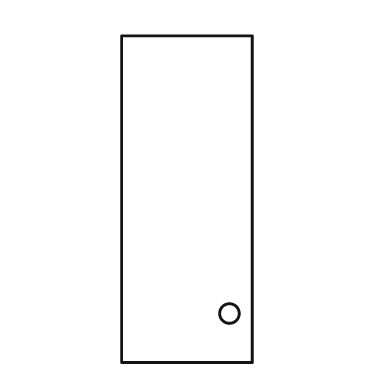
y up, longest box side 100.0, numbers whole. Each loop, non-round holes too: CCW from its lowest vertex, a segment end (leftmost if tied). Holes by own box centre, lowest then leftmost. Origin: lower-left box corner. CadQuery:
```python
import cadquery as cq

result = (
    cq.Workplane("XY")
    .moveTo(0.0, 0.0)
    .lineTo(40.0, 0.0)
    .lineTo(40.0, 100.0)
    .lineTo(0.0, 100.0)
    .close()
    .moveTo(33.0, 15.0)
    .circle(3.0)
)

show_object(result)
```